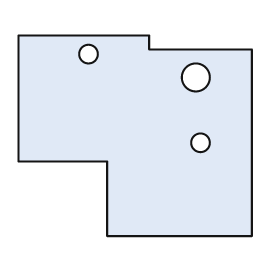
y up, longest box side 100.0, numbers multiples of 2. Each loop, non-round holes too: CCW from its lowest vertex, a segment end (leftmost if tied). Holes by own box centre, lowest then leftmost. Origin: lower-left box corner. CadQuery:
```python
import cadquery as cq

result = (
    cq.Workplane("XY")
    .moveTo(38.0, 0.0)
    .lineTo(100.0, 0.0)
    .lineTo(100.0, 80.0)
    .lineTo(56.0, 80.0)
    .lineTo(56.0, 86.0)
    .lineTo(0.0, 86.0)
    .lineTo(0.0, 32.0)
    .lineTo(38.0, 32.0)
    .close()
    .moveTo(78.0, 40.0)
    .circle(4.0)
    .moveTo(76.0, 68.0)
    .circle(6.0)
    .moveTo(30.0, 78.0)
    .circle(4.0)
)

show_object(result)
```